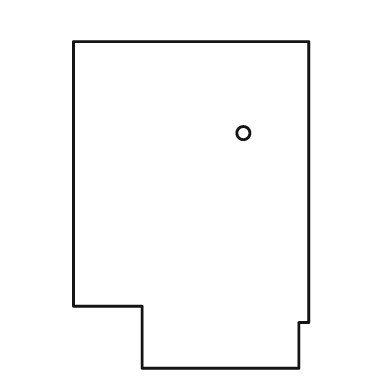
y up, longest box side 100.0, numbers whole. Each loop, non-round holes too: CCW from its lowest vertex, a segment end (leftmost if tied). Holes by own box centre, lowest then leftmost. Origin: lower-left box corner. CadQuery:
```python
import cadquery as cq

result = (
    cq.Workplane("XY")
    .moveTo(21.0, 0.0)
    .lineTo(69.0, 0.0)
    .lineTo(69.0, 14.0)
    .lineTo(72.0, 14.0)
    .lineTo(72.0, 100.0)
    .lineTo(0.0, 100.0)
    .lineTo(0.0, 19.0)
    .lineTo(21.0, 19.0)
    .close()
    .moveTo(52.0, 72.0)
    .circle(2.0)
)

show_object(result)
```